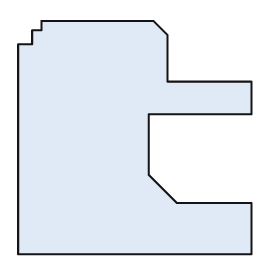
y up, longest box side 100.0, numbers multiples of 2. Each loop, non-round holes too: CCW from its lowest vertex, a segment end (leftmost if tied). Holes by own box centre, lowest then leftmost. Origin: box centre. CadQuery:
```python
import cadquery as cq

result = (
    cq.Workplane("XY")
    .moveTo(-50.0, -50.0)
    .lineTo(50.0, -50.0)
    .lineTo(50.0, -28.0)
    .lineTo(18.0, -28.0)
    .lineTo(6.0, -16.0)
    .lineTo(6.0, 10.0)
    .lineTo(50.0, 10.0)
    .lineTo(50.0, 24.0)
    .lineTo(14.0, 24.0)
    .lineTo(14.0, 44.0)
    .lineTo(8.0, 50.0)
    .lineTo(-40.0, 50.0)
    .lineTo(-40.0, 46.0)
    .lineTo(-44.0, 46.0)
    .lineTo(-44.0, 40.0)
    .lineTo(-50.0, 40.0)
    .close()
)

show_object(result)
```